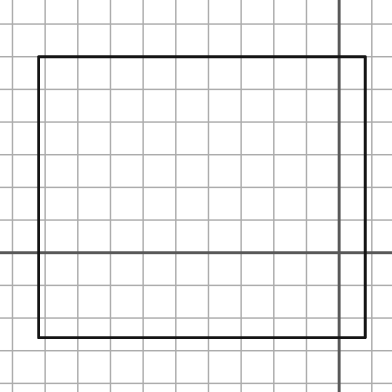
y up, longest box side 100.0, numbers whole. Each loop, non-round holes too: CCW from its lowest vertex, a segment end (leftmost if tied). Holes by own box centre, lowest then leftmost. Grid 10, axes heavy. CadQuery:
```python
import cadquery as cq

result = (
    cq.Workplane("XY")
    .moveTo(-92.0, -26.0)
    .lineTo(8.0, -26.0)
    .lineTo(8.0, 60.0)
    .lineTo(-92.0, 60.0)
    .close()
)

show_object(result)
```